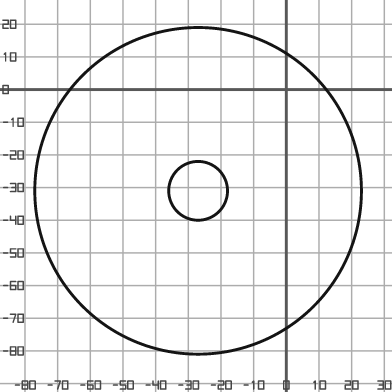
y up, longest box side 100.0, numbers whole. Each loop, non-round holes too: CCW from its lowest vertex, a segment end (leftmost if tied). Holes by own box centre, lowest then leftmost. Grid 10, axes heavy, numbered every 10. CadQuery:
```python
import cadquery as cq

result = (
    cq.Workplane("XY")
    .moveTo(-27.0, -31.0)
    .circle(50.0)
    .moveTo(-27.0, -31.0)
    .circle(9.0)
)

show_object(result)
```